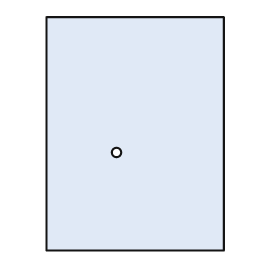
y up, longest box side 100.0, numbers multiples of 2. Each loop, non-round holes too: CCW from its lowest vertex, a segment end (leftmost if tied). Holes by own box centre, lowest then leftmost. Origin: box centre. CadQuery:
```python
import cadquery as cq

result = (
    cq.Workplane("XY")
    .moveTo(-38.0, -50.0)
    .lineTo(38.0, -50.0)
    .lineTo(38.0, 50.0)
    .lineTo(-38.0, 50.0)
    .close()
    .moveTo(-8.0, -8.0)
    .circle(2.0)
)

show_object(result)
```